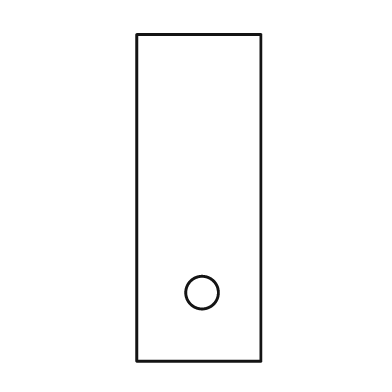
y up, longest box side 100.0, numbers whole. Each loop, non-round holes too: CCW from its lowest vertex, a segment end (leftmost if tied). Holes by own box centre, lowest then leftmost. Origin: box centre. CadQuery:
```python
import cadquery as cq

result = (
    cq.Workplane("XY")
    .moveTo(-19.0, -50.0)
    .lineTo(19.0, -50.0)
    .lineTo(19.0, 50.0)
    .lineTo(-19.0, 50.0)
    .close()
    .moveTo(1.0, -29.0)
    .circle(5.0)
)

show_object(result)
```